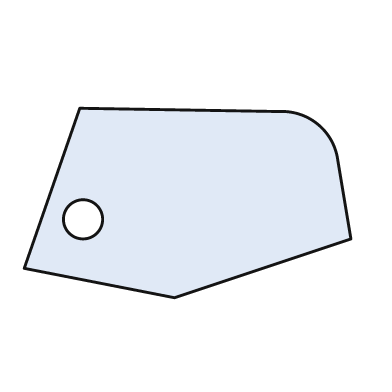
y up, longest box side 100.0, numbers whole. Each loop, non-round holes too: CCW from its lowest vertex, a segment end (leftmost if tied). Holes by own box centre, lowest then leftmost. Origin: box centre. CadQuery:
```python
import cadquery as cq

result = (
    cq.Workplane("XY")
    .moveTo(-4.0, -29.0)
    .lineTo(50.0, -11.0)
    .lineTo(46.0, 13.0)
    .threePointArc((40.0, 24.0), (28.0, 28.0))
    .lineTo(-33.0, 29.0)
    .lineTo(-50.0, -20.0)
    .close()
    .moveTo(-32.0, -5.0)
    .circle(6.0)
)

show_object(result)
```